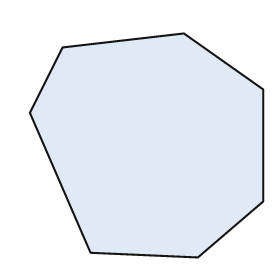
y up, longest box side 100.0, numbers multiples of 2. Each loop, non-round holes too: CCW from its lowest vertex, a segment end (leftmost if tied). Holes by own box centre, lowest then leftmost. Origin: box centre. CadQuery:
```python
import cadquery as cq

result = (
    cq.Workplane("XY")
    .moveTo(22.0, -48.0)
    .lineTo(50.0, -24.0)
    .lineTo(50.0, 24.0)
    .lineTo(16.0, 48.0)
    .lineTo(-36.0, 42.0)
    .lineTo(-50.0, 14.0)
    .lineTo(-24.0, -46.0)
    .close()
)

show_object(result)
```